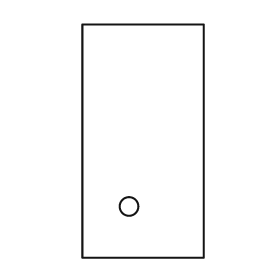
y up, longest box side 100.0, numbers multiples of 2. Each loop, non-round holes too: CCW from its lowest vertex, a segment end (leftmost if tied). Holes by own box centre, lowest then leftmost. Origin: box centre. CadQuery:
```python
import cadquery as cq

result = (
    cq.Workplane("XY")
    .moveTo(-26.0, -50.0)
    .lineTo(26.0, -50.0)
    .lineTo(26.0, 50.0)
    .lineTo(-26.0, 50.0)
    .close()
    .moveTo(-6.0, -28.0)
    .circle(4.0)
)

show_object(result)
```